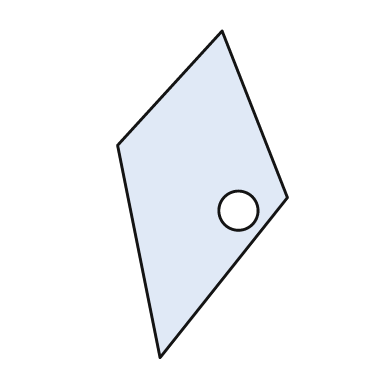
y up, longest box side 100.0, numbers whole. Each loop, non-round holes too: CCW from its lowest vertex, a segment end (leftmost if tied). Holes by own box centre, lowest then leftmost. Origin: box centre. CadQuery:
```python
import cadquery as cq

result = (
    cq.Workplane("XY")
    .moveTo(-13.0, -50.0)
    .lineTo(26.0, -1.0)
    .lineTo(6.0, 50.0)
    .lineTo(-26.0, 15.0)
    .close()
    .moveTo(11.0, -5.0)
    .circle(6.0)
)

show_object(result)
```